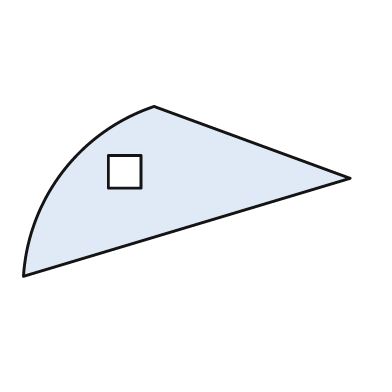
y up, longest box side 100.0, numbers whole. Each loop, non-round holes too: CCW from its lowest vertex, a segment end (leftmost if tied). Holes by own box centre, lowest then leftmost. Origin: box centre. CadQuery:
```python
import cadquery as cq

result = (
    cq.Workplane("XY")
    .moveTo(-50.0, -26.0)
    .lineTo(50.0, 4.0)
    .lineTo(-10.0, 26.0)
    .threePointArc((-38.0, 6.0), (-50.0, -26.0))
    .close()
    .moveTo(-24.0, 1.0)
    .lineTo(-14.0, 1.0)
    .lineTo(-14.0, 11.0)
    .lineTo(-24.0, 11.0)
    .close()
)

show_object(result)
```